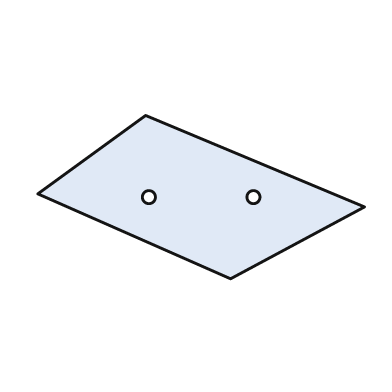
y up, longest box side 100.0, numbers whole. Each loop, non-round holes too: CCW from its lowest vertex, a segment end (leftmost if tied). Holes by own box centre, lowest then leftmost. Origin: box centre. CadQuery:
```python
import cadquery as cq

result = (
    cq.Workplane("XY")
    .moveTo(9.0, -25.0)
    .lineTo(50.0, -3.0)
    .lineTo(-17.0, 25.0)
    .lineTo(-50.0, 1.0)
    .close()
    .moveTo(-16.0, 0.0)
    .circle(2.0)
    .moveTo(16.0, 0.0)
    .circle(2.0)
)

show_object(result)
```